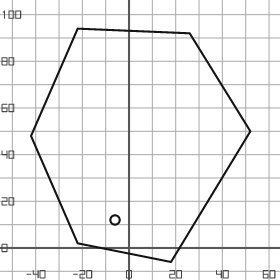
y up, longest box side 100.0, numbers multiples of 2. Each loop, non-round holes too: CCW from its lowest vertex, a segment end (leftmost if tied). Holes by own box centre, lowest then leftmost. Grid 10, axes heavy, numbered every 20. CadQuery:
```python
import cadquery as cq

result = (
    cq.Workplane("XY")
    .moveTo(18.0, -6.0)
    .lineTo(52.0, 50.0)
    .lineTo(26.0, 92.0)
    .lineTo(-22.0, 94.0)
    .lineTo(-42.0, 48.0)
    .lineTo(-22.0, 2.0)
    .close()
    .moveTo(-6.0, 12.0)
    .circle(2.0)
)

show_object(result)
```